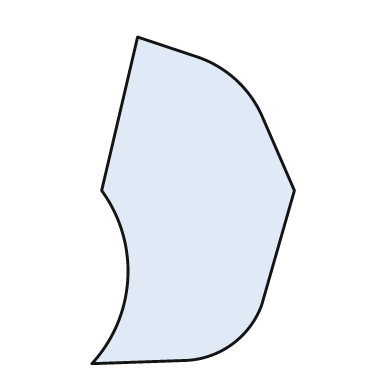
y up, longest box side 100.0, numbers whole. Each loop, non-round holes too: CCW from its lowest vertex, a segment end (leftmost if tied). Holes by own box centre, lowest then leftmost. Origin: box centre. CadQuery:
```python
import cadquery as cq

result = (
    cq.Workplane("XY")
    .moveTo(-31.0, -50.0)
    .lineTo(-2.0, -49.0)
    .threePointArc((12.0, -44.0), (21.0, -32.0))
    .lineTo(31.0, 3.0)
    .lineTo(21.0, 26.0)
    .threePointArc((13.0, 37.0), (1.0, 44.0))
    .lineTo(-17.0, 50.0)
    .lineTo(-28.0, 3.0)
    .threePointArc((-20.0, -24.0), (-31.0, -50.0))
    .close()
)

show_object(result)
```